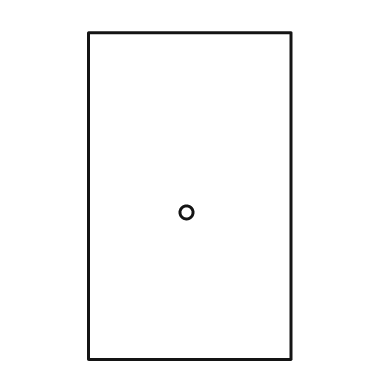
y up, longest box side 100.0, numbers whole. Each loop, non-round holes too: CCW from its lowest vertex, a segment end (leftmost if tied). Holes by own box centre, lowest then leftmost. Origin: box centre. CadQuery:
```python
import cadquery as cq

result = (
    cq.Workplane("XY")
    .moveTo(-31.0, -50.0)
    .lineTo(31.0, -50.0)
    .lineTo(31.0, 50.0)
    .lineTo(-31.0, 50.0)
    .close()
    .moveTo(-1.0, -5.0)
    .circle(2.0)
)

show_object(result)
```